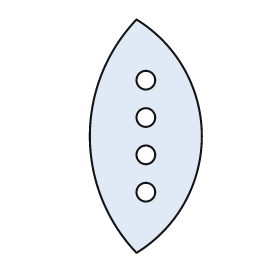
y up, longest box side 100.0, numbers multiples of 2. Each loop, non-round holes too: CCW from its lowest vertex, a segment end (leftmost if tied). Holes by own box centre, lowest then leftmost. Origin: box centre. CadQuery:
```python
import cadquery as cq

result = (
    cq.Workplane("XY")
    .moveTo(-4.0, -50.0)
    .threePointArc((24.0, 0.0), (-4.0, 50.0))
    .threePointArc((-24.0, 0.0), (-4.0, -50.0))
    .close()
    .moveTo(0.0, -24.0)
    .circle(4.0)
    .moveTo(0.0, -8.0)
    .circle(4.0)
    .moveTo(0.0, 8.0)
    .circle(4.0)
    .moveTo(0.0, 24.0)
    .circle(4.0)
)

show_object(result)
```